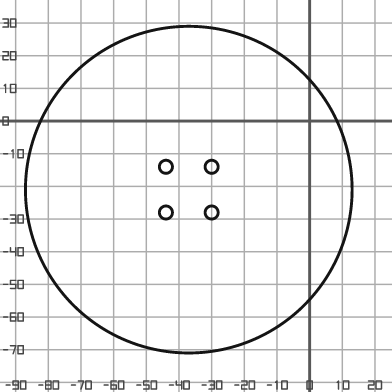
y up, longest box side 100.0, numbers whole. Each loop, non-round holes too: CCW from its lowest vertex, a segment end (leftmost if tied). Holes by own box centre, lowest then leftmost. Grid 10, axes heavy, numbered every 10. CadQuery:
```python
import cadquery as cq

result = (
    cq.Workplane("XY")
    .moveTo(-37.0, -21.0)
    .circle(50.0)
    .moveTo(-44.0, -28.0)
    .circle(2.0)
    .moveTo(-30.0, -28.0)
    .circle(2.0)
    .moveTo(-44.0, -14.0)
    .circle(2.0)
    .moveTo(-30.0, -14.0)
    .circle(2.0)
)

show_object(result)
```